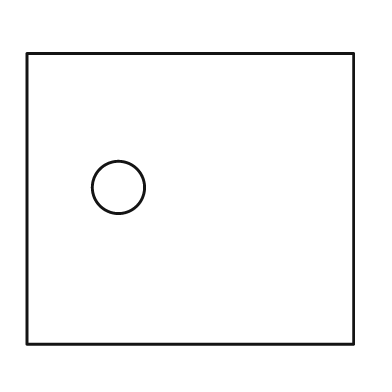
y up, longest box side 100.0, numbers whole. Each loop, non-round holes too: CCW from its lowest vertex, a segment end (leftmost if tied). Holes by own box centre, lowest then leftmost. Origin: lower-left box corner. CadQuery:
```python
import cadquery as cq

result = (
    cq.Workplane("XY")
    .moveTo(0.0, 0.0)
    .lineTo(100.0, 0.0)
    .lineTo(100.0, 89.0)
    .lineTo(0.0, 89.0)
    .close()
    .moveTo(28.0, 48.0)
    .circle(8.0)
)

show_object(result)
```